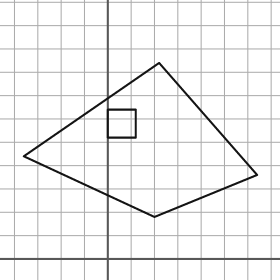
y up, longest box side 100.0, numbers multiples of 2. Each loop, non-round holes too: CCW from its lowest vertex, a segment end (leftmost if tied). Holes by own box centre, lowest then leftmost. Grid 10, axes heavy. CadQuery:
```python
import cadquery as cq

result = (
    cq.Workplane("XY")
    .moveTo(20.0, 18.0)
    .lineTo(64.0, 36.0)
    .lineTo(22.0, 84.0)
    .lineTo(-36.0, 44.0)
    .close()
    .moveTo(0.0, 52.0)
    .lineTo(12.0, 52.0)
    .lineTo(12.0, 64.0)
    .lineTo(0.0, 64.0)
    .close()
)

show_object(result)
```